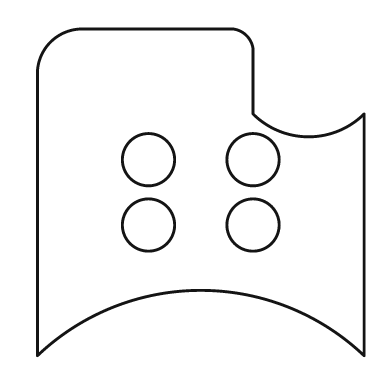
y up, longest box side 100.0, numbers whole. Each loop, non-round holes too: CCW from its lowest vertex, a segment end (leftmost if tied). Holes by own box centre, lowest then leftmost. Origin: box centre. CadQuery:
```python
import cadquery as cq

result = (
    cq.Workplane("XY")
    .moveTo(-50.0, -50.0)
    .threePointArc((0.0, -30.0), (50.0, -50.0))
    .lineTo(50.0, 24.0)
    .threePointArc((33.0, 17.0), (16.0, 24.0))
    .lineTo(16.0, 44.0)
    .threePointArc((14.0, 48.0), (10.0, 50.0))
    .lineTo(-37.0, 50.0)
    .threePointArc((-46.0, 46.0), (-50.0, 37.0))
    .close()
    .moveTo(-16.0, -10.0)
    .circle(8.0)
    .moveTo(16.0, -10.0)
    .circle(8.0)
    .moveTo(-16.0, 10.0)
    .circle(8.0)
    .moveTo(16.0, 10.0)
    .circle(8.0)
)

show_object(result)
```